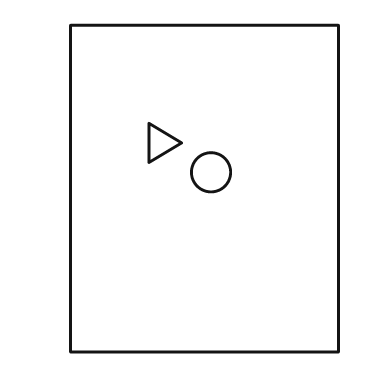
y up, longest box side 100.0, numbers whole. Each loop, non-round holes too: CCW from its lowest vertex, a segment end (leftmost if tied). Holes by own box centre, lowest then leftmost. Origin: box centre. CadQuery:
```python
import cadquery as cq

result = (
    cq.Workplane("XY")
    .moveTo(-41.0, -50.0)
    .lineTo(41.0, -50.0)
    .lineTo(41.0, 50.0)
    .lineTo(-41.0, 50.0)
    .close()
    .moveTo(2.0, 5.0)
    .circle(6.0)
    .moveTo(-17.0, 8.0)
    .lineTo(-7.0, 14.0)
    .lineTo(-17.0, 20.0)
    .close()
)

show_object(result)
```